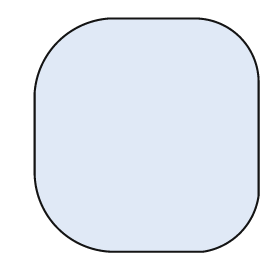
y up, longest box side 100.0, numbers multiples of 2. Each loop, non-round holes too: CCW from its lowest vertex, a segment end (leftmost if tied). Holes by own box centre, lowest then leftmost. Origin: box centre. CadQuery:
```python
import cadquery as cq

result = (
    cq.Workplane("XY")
    .moveTo(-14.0, -50.0)
    .lineTo(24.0, -50.0)
    .threePointArc((40.0, -42.0), (48.0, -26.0))
    .lineTo(48.0, 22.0)
    .threePointArc((40.0, 42.0), (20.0, 50.0))
    .lineTo(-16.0, 50.0)
    .threePointArc((-38.0, 40.0), (-48.0, 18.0))
    .lineTo(-48.0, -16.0)
    .threePointArc((-38.0, -40.0), (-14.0, -50.0))
    .close()
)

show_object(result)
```